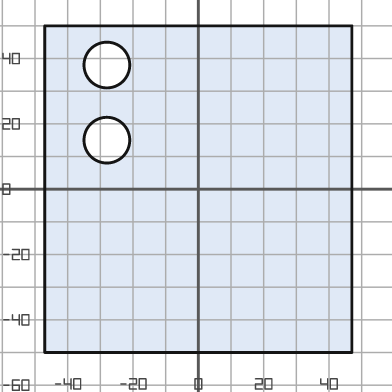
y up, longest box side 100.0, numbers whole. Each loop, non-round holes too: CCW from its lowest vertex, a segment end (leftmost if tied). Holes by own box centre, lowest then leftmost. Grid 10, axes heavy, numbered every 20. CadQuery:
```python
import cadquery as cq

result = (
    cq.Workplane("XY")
    .moveTo(-47.0, -50.0)
    .lineTo(47.0, -50.0)
    .lineTo(47.0, 50.0)
    .lineTo(-47.0, 50.0)
    .close()
    .moveTo(-28.0, 15.0)
    .circle(7.0)
    .moveTo(-28.0, 38.0)
    .circle(7.0)
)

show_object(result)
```